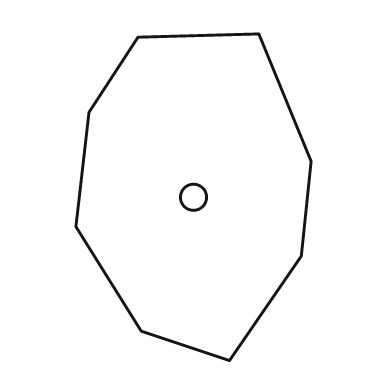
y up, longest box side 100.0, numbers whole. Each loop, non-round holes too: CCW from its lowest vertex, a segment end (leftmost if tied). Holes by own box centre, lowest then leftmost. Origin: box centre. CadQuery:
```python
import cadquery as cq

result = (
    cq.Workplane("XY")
    .moveTo(11.0, -50.0)
    .lineTo(33.0, -18.0)
    .lineTo(36.0, 11.0)
    .lineTo(20.0, 50.0)
    .lineTo(-17.0, 49.0)
    .lineTo(-32.0, 26.0)
    .lineTo(-36.0, -9.0)
    .lineTo(-16.0, -41.0)
    .close()
    .moveTo(0.0, 0.0)
    .circle(4.0)
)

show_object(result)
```